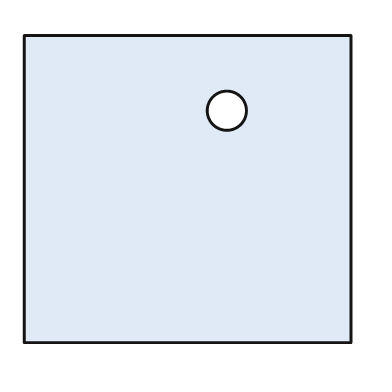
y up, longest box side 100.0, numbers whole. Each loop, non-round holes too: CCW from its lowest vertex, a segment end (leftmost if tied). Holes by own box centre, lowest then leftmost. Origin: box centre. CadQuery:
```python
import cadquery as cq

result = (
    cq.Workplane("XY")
    .moveTo(-50.0, -47.0)
    .lineTo(50.0, -47.0)
    .lineTo(50.0, 47.0)
    .lineTo(-50.0, 47.0)
    .close()
    .moveTo(12.0, 24.0)
    .circle(6.0)
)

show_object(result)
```